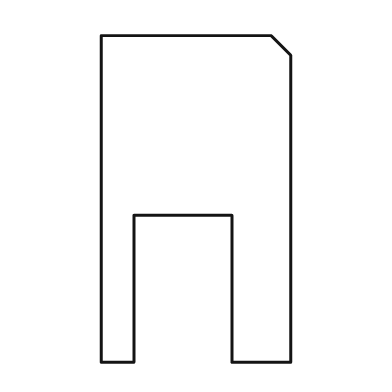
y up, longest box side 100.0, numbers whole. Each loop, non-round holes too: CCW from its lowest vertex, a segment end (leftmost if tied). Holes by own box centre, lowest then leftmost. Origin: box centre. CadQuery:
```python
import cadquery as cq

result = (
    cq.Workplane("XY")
    .moveTo(-29.0, -50.0)
    .lineTo(-19.0, -50.0)
    .lineTo(-19.0, -5.0)
    .lineTo(11.0, -5.0)
    .lineTo(11.0, -50.0)
    .lineTo(29.0, -50.0)
    .lineTo(29.0, 44.0)
    .lineTo(23.0, 50.0)
    .lineTo(-29.0, 50.0)
    .close()
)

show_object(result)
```